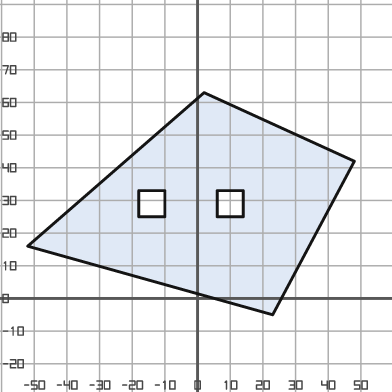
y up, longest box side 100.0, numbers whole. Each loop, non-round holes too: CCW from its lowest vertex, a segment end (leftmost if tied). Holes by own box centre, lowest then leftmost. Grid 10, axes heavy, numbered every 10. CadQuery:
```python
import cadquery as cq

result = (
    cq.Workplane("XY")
    .moveTo(23.0, -5.0)
    .lineTo(48.0, 42.0)
    .lineTo(2.0, 63.0)
    .lineTo(-52.0, 16.0)
    .close()
    .moveTo(-18.0, 25.0)
    .lineTo(-10.0, 25.0)
    .lineTo(-10.0, 33.0)
    .lineTo(-18.0, 33.0)
    .close()
    .moveTo(6.0, 25.0)
    .lineTo(14.0, 25.0)
    .lineTo(14.0, 33.0)
    .lineTo(6.0, 33.0)
    .close()
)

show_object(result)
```